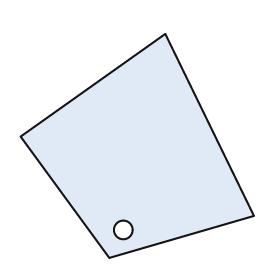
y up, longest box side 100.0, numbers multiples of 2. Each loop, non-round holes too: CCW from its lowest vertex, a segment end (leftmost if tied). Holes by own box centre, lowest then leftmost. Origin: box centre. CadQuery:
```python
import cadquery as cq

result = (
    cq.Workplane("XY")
    .moveTo(-12.0, -48.0)
    .lineTo(50.0, -30.0)
    .lineTo(12.0, 48.0)
    .lineTo(-50.0, 4.0)
    .close()
    .moveTo(-6.0, -36.0)
    .circle(4.0)
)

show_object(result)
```